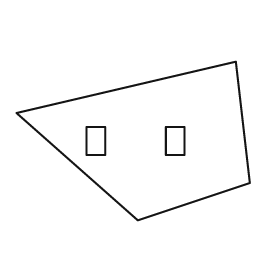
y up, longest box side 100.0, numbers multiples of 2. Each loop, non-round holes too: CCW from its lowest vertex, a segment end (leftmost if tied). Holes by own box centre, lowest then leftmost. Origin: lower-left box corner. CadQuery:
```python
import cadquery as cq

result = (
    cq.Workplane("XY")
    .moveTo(52.0, 0.0)
    .lineTo(100.0, 16.0)
    .lineTo(94.0, 68.0)
    .lineTo(0.0, 46.0)
    .close()
    .moveTo(30.0, 28.0)
    .lineTo(38.0, 28.0)
    .lineTo(38.0, 40.0)
    .lineTo(30.0, 40.0)
    .close()
    .moveTo(64.0, 28.0)
    .lineTo(72.0, 28.0)
    .lineTo(72.0, 40.0)
    .lineTo(64.0, 40.0)
    .close()
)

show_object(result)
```